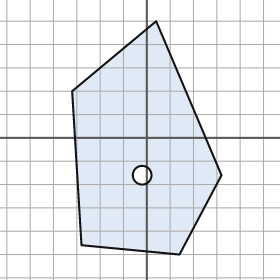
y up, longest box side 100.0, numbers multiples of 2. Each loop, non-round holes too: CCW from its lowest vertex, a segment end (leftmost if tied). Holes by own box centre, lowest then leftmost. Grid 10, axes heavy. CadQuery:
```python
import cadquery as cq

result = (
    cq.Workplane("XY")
    .moveTo(14.0, -50.0)
    .lineTo(32.0, -16.0)
    .lineTo(4.0, 50.0)
    .lineTo(-32.0, 20.0)
    .lineTo(-28.0, -46.0)
    .close()
    .moveTo(-2.0, -16.0)
    .circle(4.0)
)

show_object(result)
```